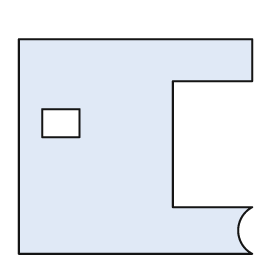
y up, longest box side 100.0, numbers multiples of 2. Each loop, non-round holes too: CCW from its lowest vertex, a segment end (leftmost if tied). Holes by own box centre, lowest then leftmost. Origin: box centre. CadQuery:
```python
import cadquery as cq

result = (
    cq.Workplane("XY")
    .moveTo(-50.0, -46.0)
    .lineTo(50.0, -46.0)
    .threePointArc((44.0, -36.0), (50.0, -26.0))
    .lineTo(16.0, -26.0)
    .lineTo(16.0, 28.0)
    .lineTo(50.0, 28.0)
    .lineTo(50.0, 46.0)
    .lineTo(-50.0, 46.0)
    .close()
    .moveTo(-40.0, 4.0)
    .lineTo(-24.0, 4.0)
    .lineTo(-24.0, 16.0)
    .lineTo(-40.0, 16.0)
    .close()
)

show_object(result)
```